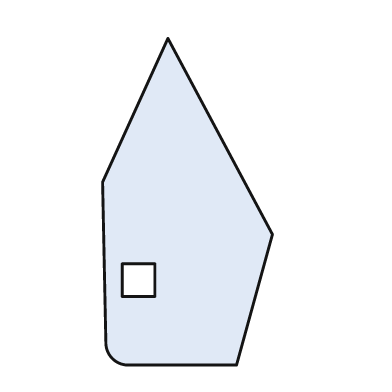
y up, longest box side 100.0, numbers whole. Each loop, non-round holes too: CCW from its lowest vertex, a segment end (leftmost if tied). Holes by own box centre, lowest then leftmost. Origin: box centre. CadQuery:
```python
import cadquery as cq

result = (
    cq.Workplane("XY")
    .moveTo(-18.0, -50.0)
    .lineTo(15.0, -50.0)
    .lineTo(26.0, -10.0)
    .lineTo(-6.0, 50.0)
    .lineTo(-26.0, 6.0)
    .lineTo(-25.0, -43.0)
    .threePointArc((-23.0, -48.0), (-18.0, -50.0))
    .close()
    .moveTo(-20.0, -29.0)
    .lineTo(-10.0, -29.0)
    .lineTo(-10.0, -19.0)
    .lineTo(-20.0, -19.0)
    .close()
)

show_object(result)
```